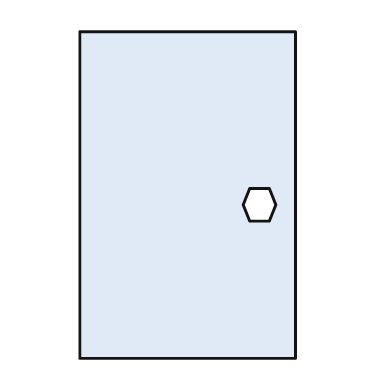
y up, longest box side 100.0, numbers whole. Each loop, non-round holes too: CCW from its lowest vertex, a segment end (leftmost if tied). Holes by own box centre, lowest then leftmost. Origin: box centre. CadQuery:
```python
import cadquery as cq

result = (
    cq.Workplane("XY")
    .moveTo(-33.0, -50.0)
    .lineTo(33.0, -50.0)
    .lineTo(33.0, 50.0)
    .lineTo(-33.0, 50.0)
    .close()
    .moveTo(19.0, -8.0)
    .lineTo(25.0, -8.0)
    .lineTo(27.0, -3.0)
    .lineTo(25.0, 2.0)
    .lineTo(19.0, 2.0)
    .lineTo(17.0, -3.0)
    .close()
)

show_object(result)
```